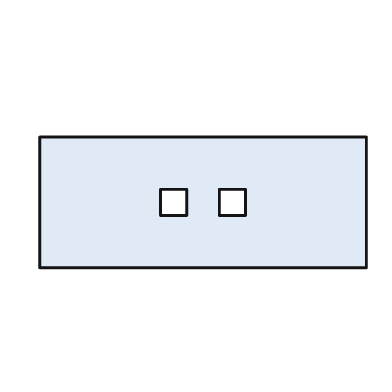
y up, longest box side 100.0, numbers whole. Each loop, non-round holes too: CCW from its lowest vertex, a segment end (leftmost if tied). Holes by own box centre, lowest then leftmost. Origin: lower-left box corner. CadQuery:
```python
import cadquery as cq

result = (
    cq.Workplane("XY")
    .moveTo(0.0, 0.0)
    .lineTo(100.0, 0.0)
    .lineTo(100.0, 40.0)
    .lineTo(0.0, 40.0)
    .close()
    .moveTo(37.0, 16.0)
    .lineTo(45.0, 16.0)
    .lineTo(45.0, 24.0)
    .lineTo(37.0, 24.0)
    .close()
    .moveTo(55.0, 16.0)
    .lineTo(63.0, 16.0)
    .lineTo(63.0, 24.0)
    .lineTo(55.0, 24.0)
    .close()
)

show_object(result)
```